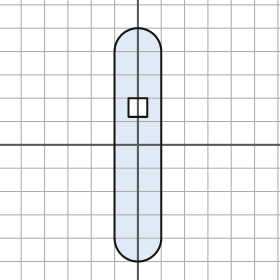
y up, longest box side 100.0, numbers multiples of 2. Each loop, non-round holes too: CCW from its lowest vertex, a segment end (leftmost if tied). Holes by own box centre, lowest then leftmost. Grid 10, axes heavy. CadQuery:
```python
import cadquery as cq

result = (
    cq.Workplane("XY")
    .moveTo(-10.0, -40.0)
    .threePointArc((0.0, -50.0), (10.0, -40.0))
    .lineTo(10.0, 40.0)
    .threePointArc((0.0, 50.0), (-10.0, 40.0))
    .close()
    .moveTo(-4.0, 12.0)
    .lineTo(4.0, 12.0)
    .lineTo(4.0, 20.0)
    .lineTo(-4.0, 20.0)
    .close()
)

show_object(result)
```